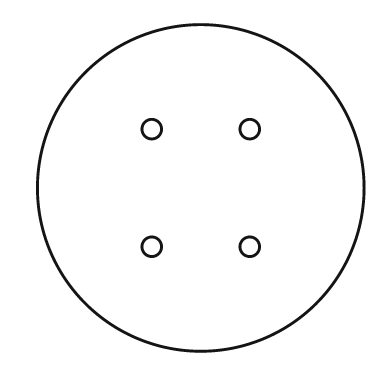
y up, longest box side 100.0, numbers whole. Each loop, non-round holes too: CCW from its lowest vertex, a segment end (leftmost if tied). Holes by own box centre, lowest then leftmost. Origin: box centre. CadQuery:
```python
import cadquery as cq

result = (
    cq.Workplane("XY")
    .moveTo(0.0, 0.0)
    .circle(50.0)
    .moveTo(-15.0, -18.0)
    .circle(3.0)
    .moveTo(15.0, -18.0)
    .circle(3.0)
    .moveTo(-15.0, 18.0)
    .circle(3.0)
    .moveTo(15.0, 18.0)
    .circle(3.0)
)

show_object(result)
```